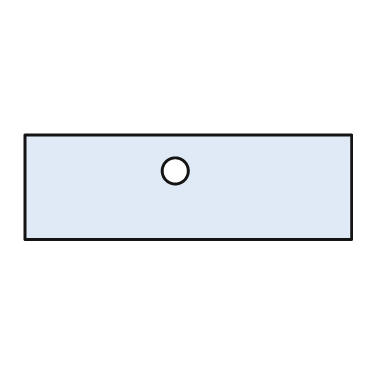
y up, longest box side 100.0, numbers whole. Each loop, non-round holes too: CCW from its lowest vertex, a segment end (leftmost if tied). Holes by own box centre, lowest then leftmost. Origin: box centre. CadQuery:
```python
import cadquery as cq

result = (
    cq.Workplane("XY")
    .moveTo(-50.0, -16.0)
    .lineTo(50.0, -16.0)
    .lineTo(50.0, 16.0)
    .lineTo(-50.0, 16.0)
    .close()
    .moveTo(-4.0, 5.0)
    .circle(4.0)
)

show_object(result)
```